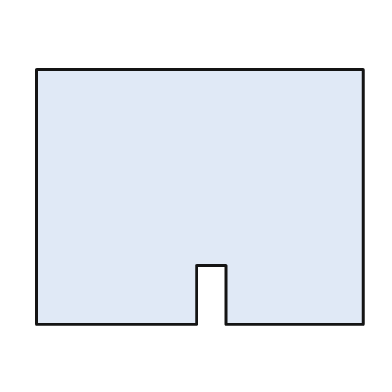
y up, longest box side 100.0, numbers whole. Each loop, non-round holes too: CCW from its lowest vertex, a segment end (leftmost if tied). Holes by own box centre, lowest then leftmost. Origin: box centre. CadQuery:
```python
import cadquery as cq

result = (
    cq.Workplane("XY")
    .moveTo(-50.0, -39.0)
    .lineTo(-1.0, -39.0)
    .lineTo(-1.0, -21.0)
    .lineTo(8.0, -21.0)
    .lineTo(8.0, -39.0)
    .lineTo(50.0, -39.0)
    .lineTo(50.0, 39.0)
    .lineTo(-50.0, 39.0)
    .close()
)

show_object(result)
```